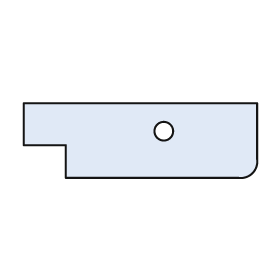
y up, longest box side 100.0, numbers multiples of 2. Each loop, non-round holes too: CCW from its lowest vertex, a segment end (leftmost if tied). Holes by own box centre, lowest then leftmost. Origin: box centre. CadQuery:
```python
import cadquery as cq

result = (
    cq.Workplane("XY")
    .moveTo(-32.0, -16.0)
    .lineTo(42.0, -16.0)
    .threePointArc((48.0, -14.0), (50.0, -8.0))
    .lineTo(50.0, 16.0)
    .lineTo(-50.0, 16.0)
    .lineTo(-50.0, -2.0)
    .lineTo(-32.0, -2.0)
    .close()
    .moveTo(10.0, 4.0)
    .circle(4.0)
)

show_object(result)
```